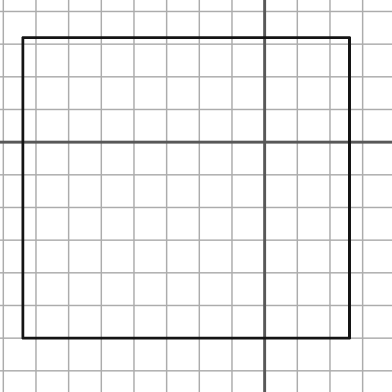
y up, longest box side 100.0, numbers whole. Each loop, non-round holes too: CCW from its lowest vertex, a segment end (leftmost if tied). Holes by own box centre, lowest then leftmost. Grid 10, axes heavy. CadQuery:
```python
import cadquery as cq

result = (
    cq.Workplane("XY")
    .moveTo(-74.0, -60.0)
    .lineTo(26.0, -60.0)
    .lineTo(26.0, 32.0)
    .lineTo(-74.0, 32.0)
    .close()
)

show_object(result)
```